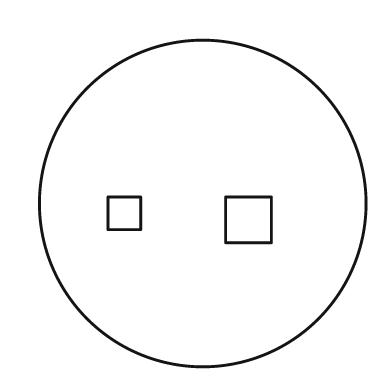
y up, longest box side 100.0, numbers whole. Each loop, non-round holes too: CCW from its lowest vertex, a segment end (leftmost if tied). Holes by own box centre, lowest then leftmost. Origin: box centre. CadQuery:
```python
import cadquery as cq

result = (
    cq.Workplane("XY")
    .moveTo(0.0, 0.0)
    .circle(50.0)
    .moveTo(7.0, -12.0)
    .lineTo(21.0, -12.0)
    .lineTo(21.0, 2.0)
    .lineTo(7.0, 2.0)
    .close()
    .moveTo(-29.0, -8.0)
    .lineTo(-19.0, -8.0)
    .lineTo(-19.0, 2.0)
    .lineTo(-29.0, 2.0)
    .close()
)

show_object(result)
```